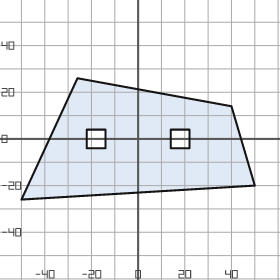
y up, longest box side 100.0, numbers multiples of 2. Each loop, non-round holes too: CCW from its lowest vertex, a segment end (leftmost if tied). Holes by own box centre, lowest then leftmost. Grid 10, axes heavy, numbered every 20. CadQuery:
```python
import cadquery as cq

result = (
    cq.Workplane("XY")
    .moveTo(-50.0, -26.0)
    .lineTo(50.0, -20.0)
    .lineTo(40.0, 14.0)
    .lineTo(-26.0, 26.0)
    .close()
    .moveTo(-22.0, -4.0)
    .lineTo(-14.0, -4.0)
    .lineTo(-14.0, 4.0)
    .lineTo(-22.0, 4.0)
    .close()
    .moveTo(14.0, -4.0)
    .lineTo(22.0, -4.0)
    .lineTo(22.0, 4.0)
    .lineTo(14.0, 4.0)
    .close()
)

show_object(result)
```